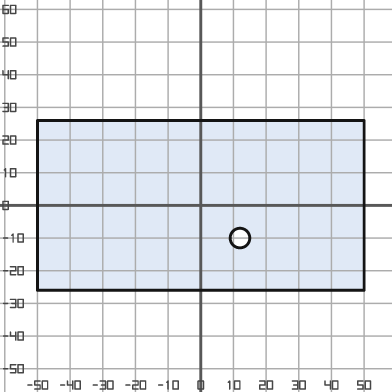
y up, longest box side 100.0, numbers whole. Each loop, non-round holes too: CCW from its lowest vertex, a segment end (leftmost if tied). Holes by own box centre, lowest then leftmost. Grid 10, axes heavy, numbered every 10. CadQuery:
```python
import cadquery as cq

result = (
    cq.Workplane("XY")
    .moveTo(-50.0, -26.0)
    .lineTo(50.0, -26.0)
    .lineTo(50.0, 26.0)
    .lineTo(-50.0, 26.0)
    .close()
    .moveTo(12.0, -10.0)
    .circle(3.0)
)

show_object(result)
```